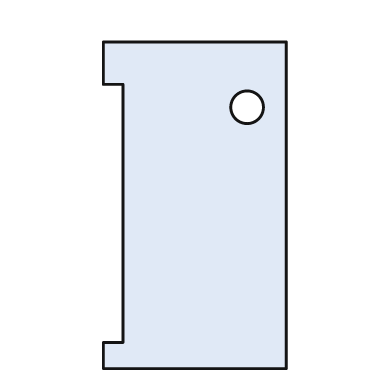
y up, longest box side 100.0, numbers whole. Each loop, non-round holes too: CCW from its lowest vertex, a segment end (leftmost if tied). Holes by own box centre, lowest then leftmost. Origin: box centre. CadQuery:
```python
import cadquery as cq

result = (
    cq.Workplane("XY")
    .moveTo(-28.0, -50.0)
    .lineTo(28.0, -50.0)
    .lineTo(28.0, 50.0)
    .lineTo(-28.0, 50.0)
    .lineTo(-28.0, 37.0)
    .lineTo(-22.0, 37.0)
    .lineTo(-22.0, -42.0)
    .lineTo(-28.0, -42.0)
    .close()
    .moveTo(16.0, 30.0)
    .circle(5.0)
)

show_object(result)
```